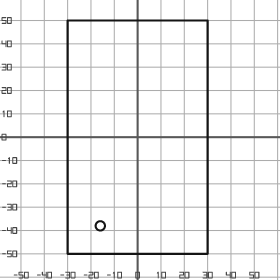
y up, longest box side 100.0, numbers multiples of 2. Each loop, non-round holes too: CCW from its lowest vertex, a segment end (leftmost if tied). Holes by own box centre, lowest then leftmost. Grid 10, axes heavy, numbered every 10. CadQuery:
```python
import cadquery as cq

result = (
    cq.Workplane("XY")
    .moveTo(-30.0, -50.0)
    .lineTo(30.0, -50.0)
    .lineTo(30.0, 50.0)
    .lineTo(-30.0, 50.0)
    .close()
    .moveTo(-16.0, -38.0)
    .circle(2.0)
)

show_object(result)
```